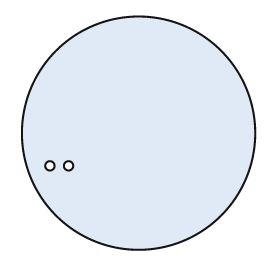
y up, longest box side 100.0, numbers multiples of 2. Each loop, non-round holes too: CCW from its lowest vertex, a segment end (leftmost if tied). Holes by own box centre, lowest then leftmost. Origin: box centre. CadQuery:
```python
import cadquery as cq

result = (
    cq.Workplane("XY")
    .moveTo(0.0, 0.0)
    .circle(50.0)
    .moveTo(-38.0, -14.0)
    .circle(2.0)
    .moveTo(-30.0, -14.0)
    .circle(2.0)
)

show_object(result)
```